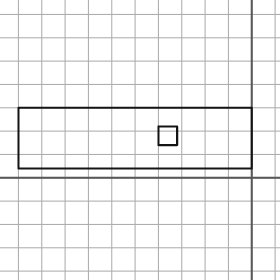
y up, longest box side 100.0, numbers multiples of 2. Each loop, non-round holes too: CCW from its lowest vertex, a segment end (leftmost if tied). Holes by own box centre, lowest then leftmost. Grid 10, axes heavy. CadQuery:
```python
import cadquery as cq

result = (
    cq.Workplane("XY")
    .moveTo(-100.0, 4.0)
    .lineTo(0.0, 4.0)
    .lineTo(0.0, 30.0)
    .lineTo(-100.0, 30.0)
    .close()
    .moveTo(-40.0, 14.0)
    .lineTo(-32.0, 14.0)
    .lineTo(-32.0, 22.0)
    .lineTo(-40.0, 22.0)
    .close()
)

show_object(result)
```